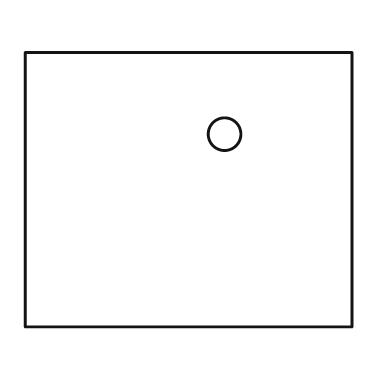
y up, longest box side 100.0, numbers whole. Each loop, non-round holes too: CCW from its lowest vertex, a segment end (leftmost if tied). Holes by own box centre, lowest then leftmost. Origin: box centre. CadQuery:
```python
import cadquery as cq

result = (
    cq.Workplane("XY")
    .moveTo(-50.0, -42.0)
    .lineTo(50.0, -42.0)
    .lineTo(50.0, 42.0)
    .lineTo(-50.0, 42.0)
    .close()
    .moveTo(11.0, 17.0)
    .circle(5.0)
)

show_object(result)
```